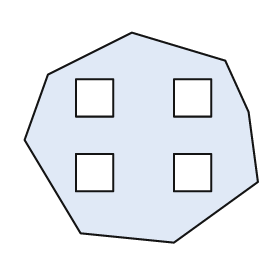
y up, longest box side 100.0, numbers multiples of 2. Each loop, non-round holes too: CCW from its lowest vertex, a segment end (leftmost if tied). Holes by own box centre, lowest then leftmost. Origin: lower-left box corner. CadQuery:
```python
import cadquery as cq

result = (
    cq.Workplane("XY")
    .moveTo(64.0, 0.0)
    .lineTo(100.0, 26.0)
    .lineTo(96.0, 56.0)
    .lineTo(86.0, 78.0)
    .lineTo(46.0, 90.0)
    .lineTo(10.0, 72.0)
    .lineTo(0.0, 44.0)
    .lineTo(24.0, 4.0)
    .close()
    .moveTo(22.0, 22.0)
    .lineTo(38.0, 22.0)
    .lineTo(38.0, 38.0)
    .lineTo(22.0, 38.0)
    .close()
    .moveTo(64.0, 22.0)
    .lineTo(80.0, 22.0)
    .lineTo(80.0, 38.0)
    .lineTo(64.0, 38.0)
    .close()
    .moveTo(22.0, 54.0)
    .lineTo(38.0, 54.0)
    .lineTo(38.0, 70.0)
    .lineTo(22.0, 70.0)
    .close()
    .moveTo(64.0, 54.0)
    .lineTo(80.0, 54.0)
    .lineTo(80.0, 70.0)
    .lineTo(64.0, 70.0)
    .close()
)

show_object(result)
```